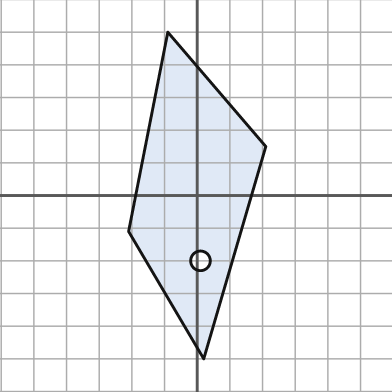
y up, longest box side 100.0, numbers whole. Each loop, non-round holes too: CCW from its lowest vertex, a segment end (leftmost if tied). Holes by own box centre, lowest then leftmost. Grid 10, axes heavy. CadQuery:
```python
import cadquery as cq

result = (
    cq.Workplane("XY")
    .moveTo(2.0, -50.0)
    .lineTo(21.0, 15.0)
    .lineTo(-9.0, 50.0)
    .lineTo(-21.0, -11.0)
    .close()
    .moveTo(1.0, -20.0)
    .circle(3.0)
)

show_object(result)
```